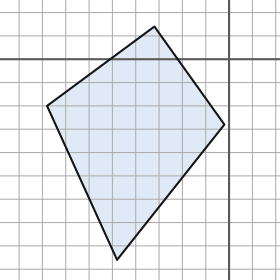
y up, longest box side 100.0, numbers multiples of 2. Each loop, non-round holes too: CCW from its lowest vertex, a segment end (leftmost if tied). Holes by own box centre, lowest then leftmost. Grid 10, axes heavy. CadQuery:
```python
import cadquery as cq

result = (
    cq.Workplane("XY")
    .moveTo(-48.0, -86.0)
    .lineTo(-2.0, -28.0)
    .lineTo(-32.0, 14.0)
    .lineTo(-78.0, -20.0)
    .close()
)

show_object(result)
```